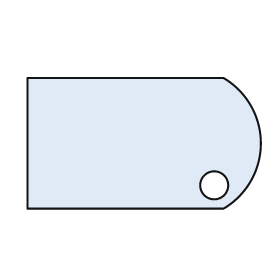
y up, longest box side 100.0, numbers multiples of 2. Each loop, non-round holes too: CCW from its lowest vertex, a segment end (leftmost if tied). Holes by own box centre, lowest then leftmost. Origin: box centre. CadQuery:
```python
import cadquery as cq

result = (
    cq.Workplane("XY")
    .moveTo(-50.0, -28.0)
    .lineTo(34.0, -28.0)
    .threePointArc((50.0, 0.0), (34.0, 28.0))
    .lineTo(-50.0, 28.0)
    .close()
    .moveTo(30.0, -18.0)
    .circle(6.0)
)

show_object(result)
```